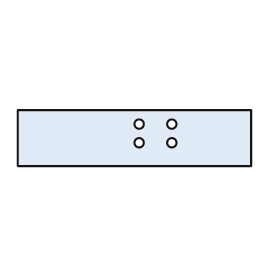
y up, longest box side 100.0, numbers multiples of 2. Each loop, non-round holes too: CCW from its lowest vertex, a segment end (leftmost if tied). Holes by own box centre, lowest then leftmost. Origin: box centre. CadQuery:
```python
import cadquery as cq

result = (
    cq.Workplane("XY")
    .moveTo(-50.0, -12.0)
    .lineTo(50.0, -12.0)
    .lineTo(50.0, 12.0)
    .lineTo(-50.0, 12.0)
    .close()
    .moveTo(2.0, -2.0)
    .circle(2.0)
    .moveTo(16.0, -2.0)
    .circle(2.0)
    .moveTo(2.0, 6.0)
    .circle(2.0)
    .moveTo(16.0, 6.0)
    .circle(2.0)
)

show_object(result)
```